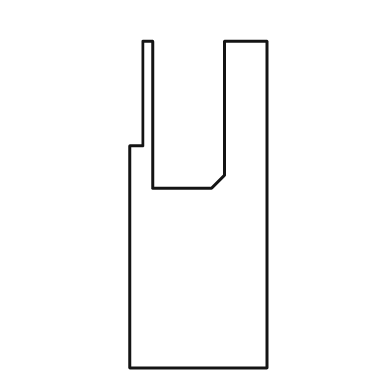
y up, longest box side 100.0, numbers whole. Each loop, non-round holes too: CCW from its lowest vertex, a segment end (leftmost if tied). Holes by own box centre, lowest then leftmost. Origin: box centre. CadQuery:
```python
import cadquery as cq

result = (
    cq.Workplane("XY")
    .moveTo(-21.0, -50.0)
    .lineTo(21.0, -50.0)
    .lineTo(21.0, 50.0)
    .lineTo(8.0, 50.0)
    .lineTo(8.0, 9.0)
    .lineTo(4.0, 5.0)
    .lineTo(-14.0, 5.0)
    .lineTo(-14.0, 50.0)
    .lineTo(-17.0, 50.0)
    .lineTo(-17.0, 18.0)
    .lineTo(-21.0, 18.0)
    .close()
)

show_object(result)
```